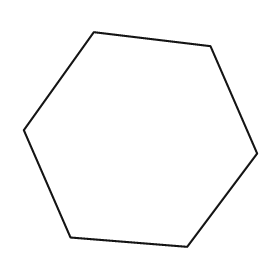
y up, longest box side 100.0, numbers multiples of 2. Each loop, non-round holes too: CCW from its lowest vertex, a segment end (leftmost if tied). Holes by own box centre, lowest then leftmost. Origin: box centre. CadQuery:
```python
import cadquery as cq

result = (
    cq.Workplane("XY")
    .moveTo(20.0, -46.0)
    .lineTo(50.0, -6.0)
    .lineTo(30.0, 40.0)
    .lineTo(-20.0, 46.0)
    .lineTo(-50.0, 4.0)
    .lineTo(-30.0, -42.0)
    .close()
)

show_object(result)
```